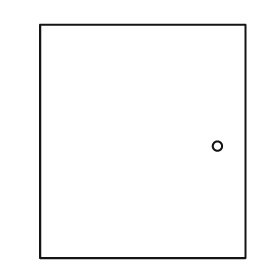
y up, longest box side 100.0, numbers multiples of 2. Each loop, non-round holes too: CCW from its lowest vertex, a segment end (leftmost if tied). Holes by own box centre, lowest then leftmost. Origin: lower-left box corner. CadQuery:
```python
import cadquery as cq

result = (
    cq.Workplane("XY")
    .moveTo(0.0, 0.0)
    .lineTo(88.0, 0.0)
    .lineTo(88.0, 100.0)
    .lineTo(0.0, 100.0)
    .close()
    .moveTo(76.0, 48.0)
    .circle(2.0)
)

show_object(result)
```